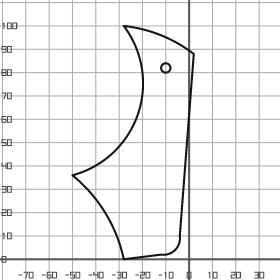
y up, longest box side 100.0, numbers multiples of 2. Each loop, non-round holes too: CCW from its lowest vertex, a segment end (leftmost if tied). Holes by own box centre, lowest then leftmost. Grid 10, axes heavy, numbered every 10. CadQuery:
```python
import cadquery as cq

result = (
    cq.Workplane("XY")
    .moveTo(-28.0, 0.0)
    .lineTo(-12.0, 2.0)
    .threePointArc((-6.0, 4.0), (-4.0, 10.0))
    .lineTo(2.0, 88.0)
    .threePointArc((-12.0, 96.0), (-28.0, 100.0))
    .threePointArc((-22.0, 62.0), (-50.0, 36.0))
    .threePointArc((-36.0, 20.0), (-28.0, 0.0))
    .close()
    .moveTo(-10.0, 82.0)
    .circle(2.0)
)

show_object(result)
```